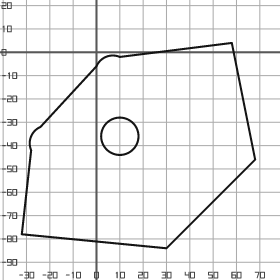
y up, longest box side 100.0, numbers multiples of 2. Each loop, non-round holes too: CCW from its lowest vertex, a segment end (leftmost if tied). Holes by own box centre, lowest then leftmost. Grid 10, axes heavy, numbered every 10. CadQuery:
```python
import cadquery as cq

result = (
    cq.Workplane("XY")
    .moveTo(30.0, -84.0)
    .lineTo(68.0, -46.0)
    .lineTo(58.0, 4.0)
    .lineTo(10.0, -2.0)
    .threePointArc((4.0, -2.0), (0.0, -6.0))
    .lineTo(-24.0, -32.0)
    .threePointArc((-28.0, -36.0), (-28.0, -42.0))
    .lineTo(-32.0, -78.0)
    .close()
    .moveTo(10.0, -36.0)
    .circle(8.0)
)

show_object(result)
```